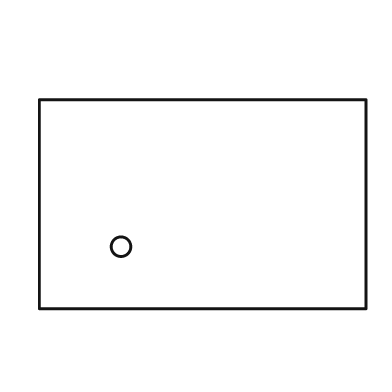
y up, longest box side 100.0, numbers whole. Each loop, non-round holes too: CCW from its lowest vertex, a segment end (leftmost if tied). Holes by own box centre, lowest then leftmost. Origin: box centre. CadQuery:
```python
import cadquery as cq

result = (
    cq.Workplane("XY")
    .moveTo(-50.0, -32.0)
    .lineTo(50.0, -32.0)
    .lineTo(50.0, 32.0)
    .lineTo(-50.0, 32.0)
    .close()
    .moveTo(-25.0, -13.0)
    .circle(3.0)
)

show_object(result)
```